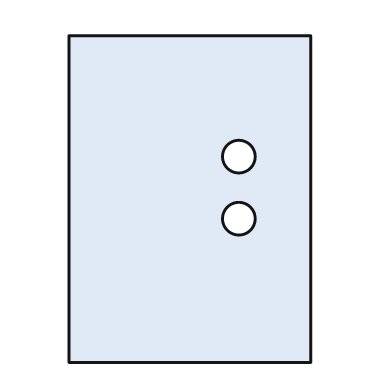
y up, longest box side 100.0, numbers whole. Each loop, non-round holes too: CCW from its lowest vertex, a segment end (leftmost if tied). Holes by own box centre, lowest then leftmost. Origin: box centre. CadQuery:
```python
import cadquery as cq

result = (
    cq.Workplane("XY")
    .moveTo(-37.0, -50.0)
    .lineTo(37.0, -50.0)
    .lineTo(37.0, 50.0)
    .lineTo(-37.0, 50.0)
    .close()
    .moveTo(15.0, -6.0)
    .circle(5.0)
    .moveTo(15.0, 13.0)
    .circle(5.0)
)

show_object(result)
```